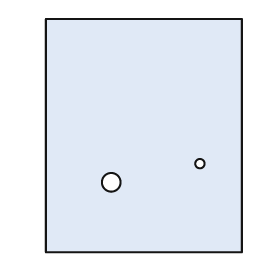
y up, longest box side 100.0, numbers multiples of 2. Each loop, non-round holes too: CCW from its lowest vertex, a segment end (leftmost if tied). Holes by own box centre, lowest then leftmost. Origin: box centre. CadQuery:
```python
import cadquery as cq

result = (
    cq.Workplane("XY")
    .moveTo(-42.0, -50.0)
    .lineTo(42.0, -50.0)
    .lineTo(42.0, 50.0)
    .lineTo(-42.0, 50.0)
    .close()
    .moveTo(-14.0, -20.0)
    .circle(4.0)
    .moveTo(24.0, -12.0)
    .circle(2.0)
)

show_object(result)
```